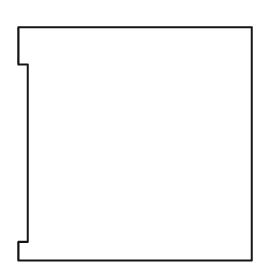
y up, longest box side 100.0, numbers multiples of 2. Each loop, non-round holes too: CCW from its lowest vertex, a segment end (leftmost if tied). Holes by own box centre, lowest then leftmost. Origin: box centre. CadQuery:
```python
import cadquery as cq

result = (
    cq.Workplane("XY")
    .moveTo(-50.0, -50.0)
    .lineTo(50.0, -50.0)
    .lineTo(50.0, 50.0)
    .lineTo(-50.0, 50.0)
    .lineTo(-50.0, 34.0)
    .lineTo(-46.0, 34.0)
    .lineTo(-46.0, -42.0)
    .lineTo(-50.0, -42.0)
    .close()
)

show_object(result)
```